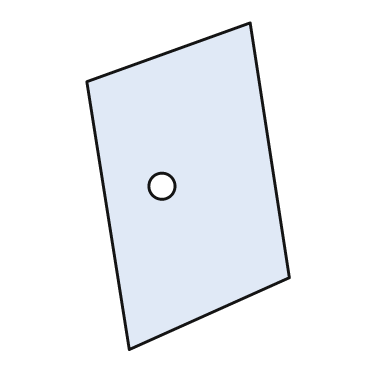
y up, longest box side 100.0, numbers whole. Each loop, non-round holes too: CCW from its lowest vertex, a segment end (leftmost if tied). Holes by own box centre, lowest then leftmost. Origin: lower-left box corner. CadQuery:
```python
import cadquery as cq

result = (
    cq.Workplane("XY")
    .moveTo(13.0, 0.0)
    .lineTo(62.0, 22.0)
    .lineTo(50.0, 100.0)
    .lineTo(0.0, 82.0)
    .close()
    .moveTo(23.0, 50.0)
    .circle(4.0)
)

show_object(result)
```